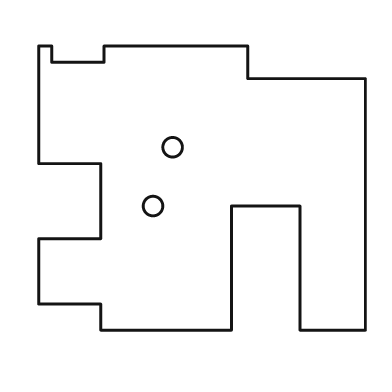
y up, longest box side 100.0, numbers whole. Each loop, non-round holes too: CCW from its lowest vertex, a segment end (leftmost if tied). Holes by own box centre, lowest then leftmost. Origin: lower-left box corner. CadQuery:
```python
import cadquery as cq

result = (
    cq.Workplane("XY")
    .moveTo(19.0, 0.0)
    .lineTo(59.0, 0.0)
    .lineTo(59.0, 38.0)
    .lineTo(80.0, 38.0)
    .lineTo(80.0, 0.0)
    .lineTo(100.0, 0.0)
    .lineTo(100.0, 77.0)
    .lineTo(64.0, 77.0)
    .lineTo(64.0, 87.0)
    .lineTo(20.0, 87.0)
    .lineTo(20.0, 82.0)
    .lineTo(4.0, 82.0)
    .lineTo(4.0, 87.0)
    .lineTo(0.0, 87.0)
    .lineTo(0.0, 51.0)
    .lineTo(19.0, 51.0)
    .lineTo(19.0, 28.0)
    .lineTo(0.0, 28.0)
    .lineTo(0.0, 8.0)
    .lineTo(19.0, 8.0)
    .close()
    .moveTo(35.0, 38.0)
    .circle(3.0)
    .moveTo(41.0, 56.0)
    .circle(3.0)
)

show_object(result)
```